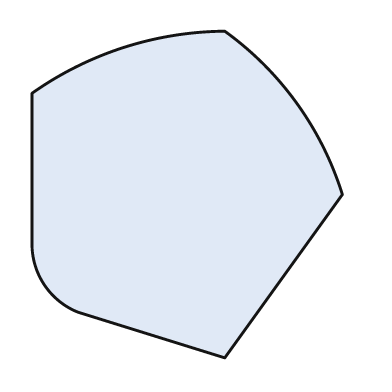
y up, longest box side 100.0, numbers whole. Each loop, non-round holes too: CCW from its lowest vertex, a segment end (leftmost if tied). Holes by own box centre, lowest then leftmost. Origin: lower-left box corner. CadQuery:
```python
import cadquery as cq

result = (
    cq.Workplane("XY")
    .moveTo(59.0, 0.0)
    .lineTo(95.0, 50.0)
    .threePointArc((81.0, 78.0), (59.0, 100.0))
    .threePointArc((28.0, 95.0), (0.0, 81.0))
    .lineTo(0.0, 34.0)
    .threePointArc((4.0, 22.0), (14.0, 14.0))
    .close()
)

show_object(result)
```